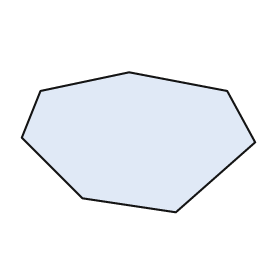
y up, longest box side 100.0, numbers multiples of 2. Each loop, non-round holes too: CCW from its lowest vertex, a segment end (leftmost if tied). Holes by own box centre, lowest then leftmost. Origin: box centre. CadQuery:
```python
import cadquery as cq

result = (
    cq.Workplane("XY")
    .moveTo(16.0, -30.0)
    .lineTo(50.0, 0.0)
    .lineTo(38.0, 22.0)
    .lineTo(-4.0, 30.0)
    .lineTo(-42.0, 22.0)
    .lineTo(-50.0, 2.0)
    .lineTo(-24.0, -24.0)
    .close()
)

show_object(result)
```